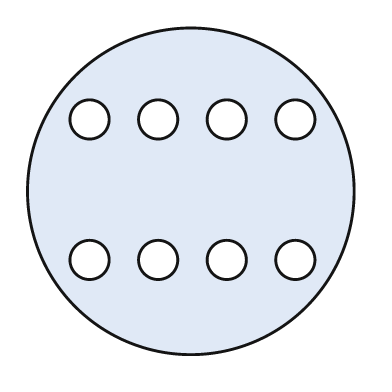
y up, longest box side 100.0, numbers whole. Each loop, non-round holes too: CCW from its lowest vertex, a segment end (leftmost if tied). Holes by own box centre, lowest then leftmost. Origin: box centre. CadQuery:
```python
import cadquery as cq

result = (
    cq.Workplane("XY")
    .moveTo(0.0, 0.0)
    .circle(50.0)
    .moveTo(-31.0, -21.0)
    .circle(6.0)
    .moveTo(-10.0, -21.0)
    .circle(6.0)
    .moveTo(11.0, -21.0)
    .circle(6.0)
    .moveTo(32.0, -21.0)
    .circle(6.0)
    .moveTo(-31.0, 22.0)
    .circle(6.0)
    .moveTo(-10.0, 22.0)
    .circle(6.0)
    .moveTo(11.0, 22.0)
    .circle(6.0)
    .moveTo(32.0, 22.0)
    .circle(6.0)
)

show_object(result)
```